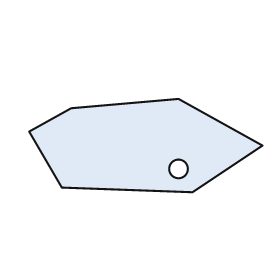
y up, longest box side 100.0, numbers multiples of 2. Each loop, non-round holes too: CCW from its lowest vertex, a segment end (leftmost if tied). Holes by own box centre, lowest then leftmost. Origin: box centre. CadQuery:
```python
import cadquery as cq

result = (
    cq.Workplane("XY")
    .moveTo(20.0, -20.0)
    .lineTo(50.0, 0.0)
    .lineTo(14.0, 20.0)
    .lineTo(-32.0, 16.0)
    .lineTo(-50.0, 6.0)
    .lineTo(-36.0, -18.0)
    .close()
    .moveTo(14.0, -10.0)
    .circle(4.0)
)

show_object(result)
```